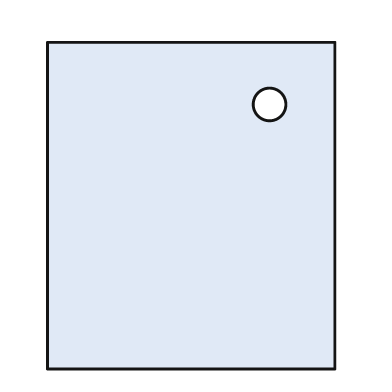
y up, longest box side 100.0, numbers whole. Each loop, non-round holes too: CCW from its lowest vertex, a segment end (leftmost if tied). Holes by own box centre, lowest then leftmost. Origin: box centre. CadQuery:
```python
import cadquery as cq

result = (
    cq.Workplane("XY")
    .moveTo(-44.0, -50.0)
    .lineTo(44.0, -50.0)
    .lineTo(44.0, 50.0)
    .lineTo(-44.0, 50.0)
    .close()
    .moveTo(24.0, 31.0)
    .circle(5.0)
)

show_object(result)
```